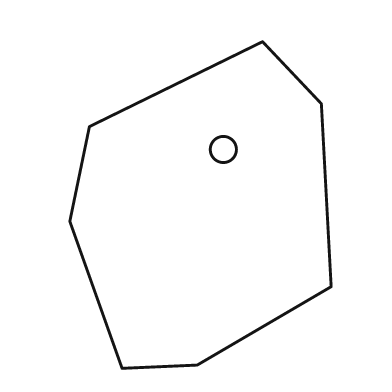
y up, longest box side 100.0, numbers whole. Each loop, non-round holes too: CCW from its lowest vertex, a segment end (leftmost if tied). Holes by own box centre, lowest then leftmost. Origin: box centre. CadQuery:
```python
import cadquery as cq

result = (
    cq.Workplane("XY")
    .moveTo(-24.0, -50.0)
    .lineTo(-1.0, -49.0)
    .lineTo(40.0, -25.0)
    .lineTo(37.0, 31.0)
    .lineTo(19.0, 50.0)
    .lineTo(-34.0, 24.0)
    .lineTo(-40.0, -5.0)
    .close()
    .moveTo(7.0, 17.0)
    .circle(4.0)
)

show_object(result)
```